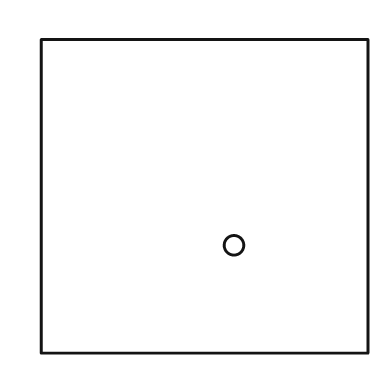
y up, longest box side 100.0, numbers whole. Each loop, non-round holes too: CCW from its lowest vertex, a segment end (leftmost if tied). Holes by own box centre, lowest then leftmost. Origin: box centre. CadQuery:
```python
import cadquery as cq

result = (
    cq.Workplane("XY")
    .moveTo(-50.0, -48.0)
    .lineTo(50.0, -48.0)
    .lineTo(50.0, 48.0)
    .lineTo(-50.0, 48.0)
    .close()
    .moveTo(9.0, -15.0)
    .circle(3.0)
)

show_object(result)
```